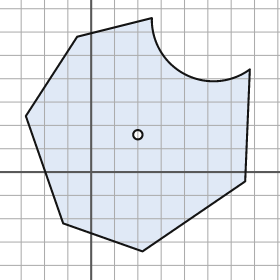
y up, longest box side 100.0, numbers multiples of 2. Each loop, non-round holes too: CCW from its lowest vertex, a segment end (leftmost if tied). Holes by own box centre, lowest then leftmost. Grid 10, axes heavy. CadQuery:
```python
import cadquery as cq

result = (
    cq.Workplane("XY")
    .moveTo(22.0, -34.0)
    .lineTo(66.0, -4.0)
    .lineTo(68.0, 44.0)
    .threePointArc((40.0, 42.0), (26.0, 66.0))
    .lineTo(-6.0, 58.0)
    .lineTo(-28.0, 24.0)
    .lineTo(-12.0, -22.0)
    .close()
    .moveTo(20.0, 16.0)
    .circle(2.0)
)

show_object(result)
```